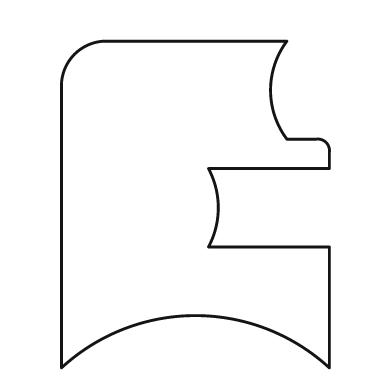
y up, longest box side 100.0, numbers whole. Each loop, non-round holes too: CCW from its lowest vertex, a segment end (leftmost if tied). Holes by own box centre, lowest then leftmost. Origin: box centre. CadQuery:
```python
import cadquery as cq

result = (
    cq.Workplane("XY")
    .moveTo(-41.0, -50.0)
    .threePointArc((0.0, -34.0), (41.0, -50.0))
    .lineTo(41.0, -13.0)
    .lineTo(4.0, -13.0)
    .threePointArc((7.0, -1.0), (4.0, 11.0))
    .lineTo(41.0, 11.0)
    .lineTo(41.0, 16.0)
    .threePointArc((40.0, 19.0), (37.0, 20.0))
    .lineTo(28.0, 20.0)
    .threePointArc((23.0, 35.0), (28.0, 50.0))
    .lineTo(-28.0, 50.0)
    .threePointArc((-37.0, 46.0), (-41.0, 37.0))
    .close()
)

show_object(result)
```